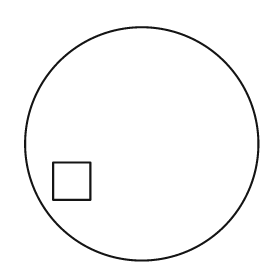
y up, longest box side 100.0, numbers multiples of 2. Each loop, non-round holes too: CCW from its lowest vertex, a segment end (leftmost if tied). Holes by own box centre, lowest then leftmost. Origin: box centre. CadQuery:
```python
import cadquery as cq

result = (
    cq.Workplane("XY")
    .moveTo(0.0, 0.0)
    .circle(50.0)
    .moveTo(-38.0, -24.0)
    .lineTo(-22.0, -24.0)
    .lineTo(-22.0, -8.0)
    .lineTo(-38.0, -8.0)
    .close()
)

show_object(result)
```